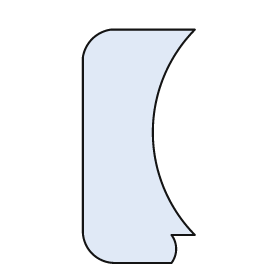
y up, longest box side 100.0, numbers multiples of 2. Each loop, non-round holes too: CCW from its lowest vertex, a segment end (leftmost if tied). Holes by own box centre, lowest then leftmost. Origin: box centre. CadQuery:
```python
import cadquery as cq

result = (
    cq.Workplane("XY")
    .moveTo(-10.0, -50.0)
    .lineTo(14.0, -50.0)
    .threePointArc((16.0, -44.0), (14.0, -38.0))
    .lineTo(24.0, -38.0)
    .threePointArc((6.0, 6.0), (24.0, 50.0))
    .lineTo(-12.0, 50.0)
    .threePointArc((-20.0, 46.0), (-24.0, 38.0))
    .lineTo(-24.0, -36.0)
    .threePointArc((-20.0, -46.0), (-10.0, -50.0))
    .close()
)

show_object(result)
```